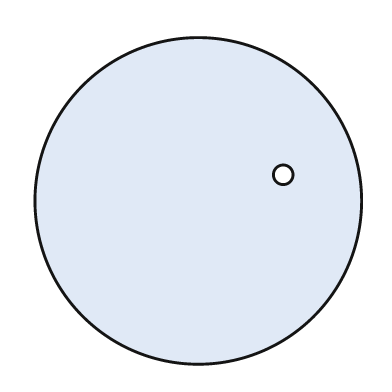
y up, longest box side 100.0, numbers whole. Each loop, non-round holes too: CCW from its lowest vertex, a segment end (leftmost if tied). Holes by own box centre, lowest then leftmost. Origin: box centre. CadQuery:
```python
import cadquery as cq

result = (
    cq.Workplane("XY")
    .moveTo(0.0, 0.0)
    .circle(50.0)
    .moveTo(26.0, 8.0)
    .circle(3.0)
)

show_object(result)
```